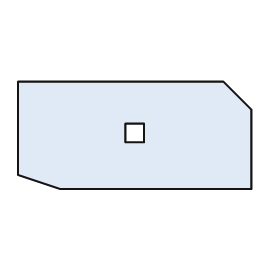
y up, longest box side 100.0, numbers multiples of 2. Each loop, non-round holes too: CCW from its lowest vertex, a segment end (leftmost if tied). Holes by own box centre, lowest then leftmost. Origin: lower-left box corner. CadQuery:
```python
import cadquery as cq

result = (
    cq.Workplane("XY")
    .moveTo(18.0, 0.0)
    .lineTo(100.0, 0.0)
    .lineTo(100.0, 34.0)
    .lineTo(88.0, 46.0)
    .lineTo(0.0, 46.0)
    .lineTo(0.0, 6.0)
    .close()
    .moveTo(46.0, 20.0)
    .lineTo(54.0, 20.0)
    .lineTo(54.0, 28.0)
    .lineTo(46.0, 28.0)
    .close()
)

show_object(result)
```